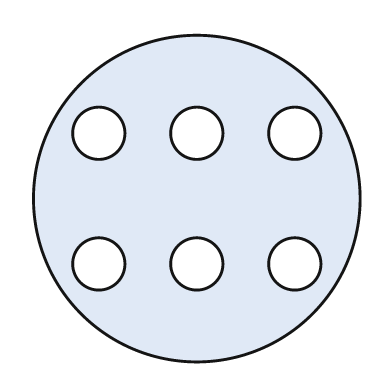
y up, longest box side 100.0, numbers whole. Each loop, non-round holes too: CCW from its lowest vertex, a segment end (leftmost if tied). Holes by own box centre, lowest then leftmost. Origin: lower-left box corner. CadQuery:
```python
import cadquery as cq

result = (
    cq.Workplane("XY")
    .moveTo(50.0, 50.0)
    .circle(50.0)
    .moveTo(20.0, 30.0)
    .circle(8.0)
    .moveTo(50.0, 30.0)
    .circle(8.0)
    .moveTo(80.0, 30.0)
    .circle(8.0)
    .moveTo(20.0, 70.0)
    .circle(8.0)
    .moveTo(50.0, 70.0)
    .circle(8.0)
    .moveTo(80.0, 70.0)
    .circle(8.0)
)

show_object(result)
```